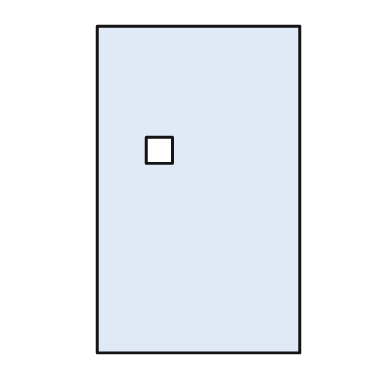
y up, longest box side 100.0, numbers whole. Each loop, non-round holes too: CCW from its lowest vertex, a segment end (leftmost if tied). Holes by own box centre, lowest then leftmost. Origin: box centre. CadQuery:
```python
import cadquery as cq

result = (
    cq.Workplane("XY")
    .moveTo(-31.0, -50.0)
    .lineTo(31.0, -50.0)
    .lineTo(31.0, 50.0)
    .lineTo(-31.0, 50.0)
    .close()
    .moveTo(-16.0, 8.0)
    .lineTo(-8.0, 8.0)
    .lineTo(-8.0, 16.0)
    .lineTo(-16.0, 16.0)
    .close()
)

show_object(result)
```